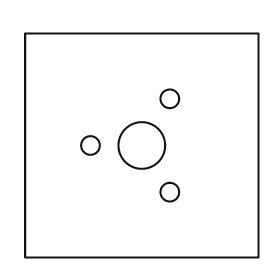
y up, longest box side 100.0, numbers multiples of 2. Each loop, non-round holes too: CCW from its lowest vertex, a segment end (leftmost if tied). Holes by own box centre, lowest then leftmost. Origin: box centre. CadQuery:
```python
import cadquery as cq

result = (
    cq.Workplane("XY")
    .moveTo(-50.0, -48.0)
    .lineTo(50.0, -48.0)
    .lineTo(50.0, 48.0)
    .lineTo(-50.0, 48.0)
    .close()
    .moveTo(12.0, -20.0)
    .circle(4.0)
    .moveTo(-22.0, 0.0)
    .circle(4.0)
    .moveTo(0.0, 0.0)
    .circle(10.0)
    .moveTo(12.0, 20.0)
    .circle(4.0)
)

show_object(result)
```